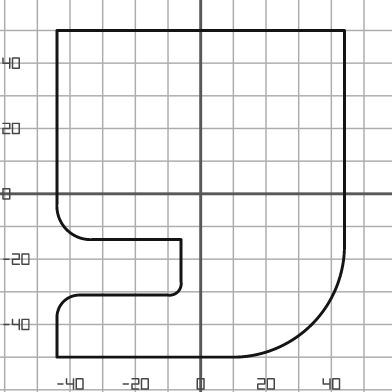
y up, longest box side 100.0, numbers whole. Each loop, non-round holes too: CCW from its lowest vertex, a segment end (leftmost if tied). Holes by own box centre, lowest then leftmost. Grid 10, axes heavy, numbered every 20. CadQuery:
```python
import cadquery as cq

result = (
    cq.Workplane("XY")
    .moveTo(-44.0, -50.0)
    .lineTo(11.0, -50.0)
    .threePointArc((34.0, -40.0), (44.0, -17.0))
    .lineTo(44.0, 50.0)
    .lineTo(-44.0, 50.0)
    .lineTo(-44.0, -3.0)
    .threePointArc((-41.0, -11.0), (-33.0, -14.0))
    .lineTo(-6.0, -14.0)
    .lineTo(-6.0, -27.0)
    .threePointArc((-7.0, -30.0), (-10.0, -31.0))
    .lineTo(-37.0, -31.0)
    .threePointArc((-42.0, -33.0), (-44.0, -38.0))
    .close()
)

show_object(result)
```